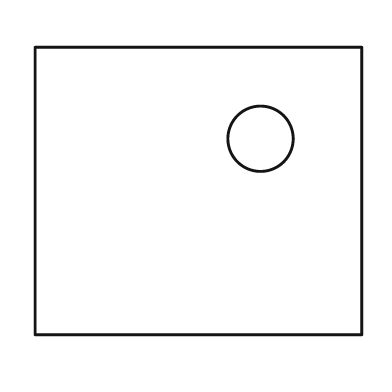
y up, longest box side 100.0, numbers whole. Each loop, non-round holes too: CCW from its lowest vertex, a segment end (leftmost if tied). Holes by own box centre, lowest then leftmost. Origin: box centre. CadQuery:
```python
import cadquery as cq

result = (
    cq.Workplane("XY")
    .moveTo(-50.0, -44.0)
    .lineTo(50.0, -44.0)
    .lineTo(50.0, 44.0)
    .lineTo(-50.0, 44.0)
    .close()
    .moveTo(19.0, 16.0)
    .circle(10.0)
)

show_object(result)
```